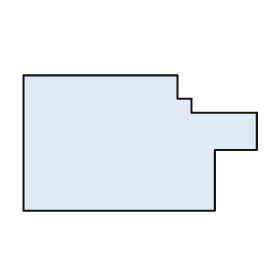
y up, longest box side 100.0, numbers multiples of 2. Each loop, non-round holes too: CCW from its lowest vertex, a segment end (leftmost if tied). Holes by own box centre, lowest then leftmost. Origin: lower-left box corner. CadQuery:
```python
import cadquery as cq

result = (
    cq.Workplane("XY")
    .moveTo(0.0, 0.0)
    .lineTo(82.0, 0.0)
    .lineTo(82.0, 26.0)
    .lineTo(100.0, 26.0)
    .lineTo(100.0, 42.0)
    .lineTo(72.0, 42.0)
    .lineTo(72.0, 48.0)
    .lineTo(66.0, 48.0)
    .lineTo(66.0, 58.0)
    .lineTo(0.0, 58.0)
    .close()
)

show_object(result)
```